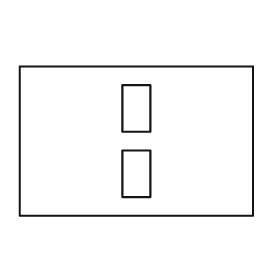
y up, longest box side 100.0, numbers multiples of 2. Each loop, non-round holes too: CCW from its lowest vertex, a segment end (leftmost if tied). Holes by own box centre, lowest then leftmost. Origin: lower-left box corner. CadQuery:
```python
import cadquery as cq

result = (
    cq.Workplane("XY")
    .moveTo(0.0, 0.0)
    .lineTo(100.0, 0.0)
    .lineTo(100.0, 64.0)
    .lineTo(0.0, 64.0)
    .close()
    .moveTo(44.0, 8.0)
    .lineTo(56.0, 8.0)
    .lineTo(56.0, 28.0)
    .lineTo(44.0, 28.0)
    .close()
    .moveTo(44.0, 36.0)
    .lineTo(56.0, 36.0)
    .lineTo(56.0, 56.0)
    .lineTo(44.0, 56.0)
    .close()
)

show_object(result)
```